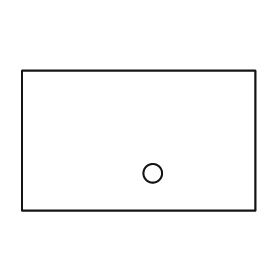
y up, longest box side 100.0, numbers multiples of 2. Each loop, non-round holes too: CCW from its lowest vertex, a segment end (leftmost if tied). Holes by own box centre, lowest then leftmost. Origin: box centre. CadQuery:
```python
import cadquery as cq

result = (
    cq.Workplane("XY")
    .moveTo(-50.0, -30.0)
    .lineTo(50.0, -30.0)
    .lineTo(50.0, 30.0)
    .lineTo(-50.0, 30.0)
    .close()
    .moveTo(6.0, -14.0)
    .circle(4.0)
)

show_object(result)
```